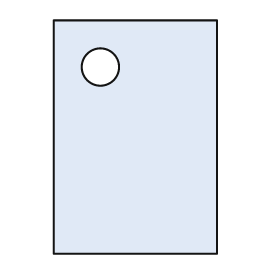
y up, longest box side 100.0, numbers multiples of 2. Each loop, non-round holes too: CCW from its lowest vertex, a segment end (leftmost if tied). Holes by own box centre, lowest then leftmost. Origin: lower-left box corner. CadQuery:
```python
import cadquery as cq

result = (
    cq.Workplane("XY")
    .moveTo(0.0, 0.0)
    .lineTo(70.0, 0.0)
    .lineTo(70.0, 100.0)
    .lineTo(0.0, 100.0)
    .close()
    .moveTo(20.0, 80.0)
    .circle(8.0)
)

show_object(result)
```